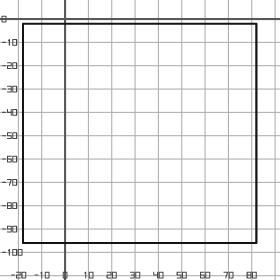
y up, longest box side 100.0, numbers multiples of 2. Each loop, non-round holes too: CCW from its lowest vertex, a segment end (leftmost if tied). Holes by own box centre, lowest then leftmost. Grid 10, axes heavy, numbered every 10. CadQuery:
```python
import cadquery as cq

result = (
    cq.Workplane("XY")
    .moveTo(-18.0, -96.0)
    .lineTo(82.0, -96.0)
    .lineTo(82.0, -2.0)
    .lineTo(-18.0, -2.0)
    .close()
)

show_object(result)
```